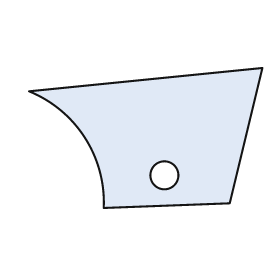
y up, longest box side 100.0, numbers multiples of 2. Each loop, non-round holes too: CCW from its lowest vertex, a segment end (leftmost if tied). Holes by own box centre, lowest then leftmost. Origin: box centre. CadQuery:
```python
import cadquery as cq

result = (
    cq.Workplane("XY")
    .moveTo(-18.0, -30.0)
    .lineTo(36.0, -28.0)
    .lineTo(50.0, 30.0)
    .lineTo(-50.0, 20.0)
    .threePointArc((-26.0, 0.0), (-18.0, -30.0))
    .close()
    .moveTo(8.0, -16.0)
    .circle(6.0)
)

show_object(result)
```